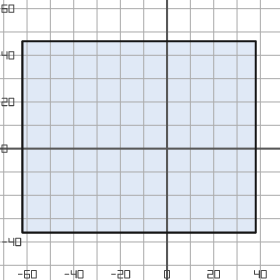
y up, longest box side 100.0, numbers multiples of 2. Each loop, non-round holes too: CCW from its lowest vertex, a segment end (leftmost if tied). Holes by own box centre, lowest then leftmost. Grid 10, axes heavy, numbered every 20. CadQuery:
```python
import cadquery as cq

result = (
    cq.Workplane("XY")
    .moveTo(-62.0, -36.0)
    .lineTo(38.0, -36.0)
    .lineTo(38.0, 46.0)
    .lineTo(-62.0, 46.0)
    .close()
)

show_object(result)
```